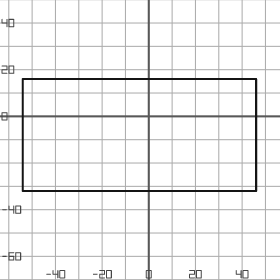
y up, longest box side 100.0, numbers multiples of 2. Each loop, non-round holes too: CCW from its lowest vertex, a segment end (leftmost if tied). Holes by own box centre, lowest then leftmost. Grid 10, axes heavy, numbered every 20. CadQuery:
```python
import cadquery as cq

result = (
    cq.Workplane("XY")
    .moveTo(-54.0, -32.0)
    .lineTo(46.0, -32.0)
    .lineTo(46.0, 16.0)
    .lineTo(-54.0, 16.0)
    .close()
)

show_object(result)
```